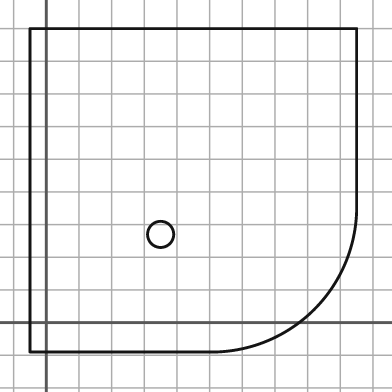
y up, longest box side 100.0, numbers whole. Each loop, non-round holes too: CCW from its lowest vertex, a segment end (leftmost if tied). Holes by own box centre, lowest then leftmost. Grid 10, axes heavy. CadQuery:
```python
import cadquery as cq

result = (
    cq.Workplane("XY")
    .moveTo(-5.0, -9.0)
    .lineTo(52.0, -9.0)
    .threePointArc((82.0, 4.0), (95.0, 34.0))
    .lineTo(95.0, 90.0)
    .lineTo(-5.0, 90.0)
    .close()
    .moveTo(35.0, 27.0)
    .circle(4.0)
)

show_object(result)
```